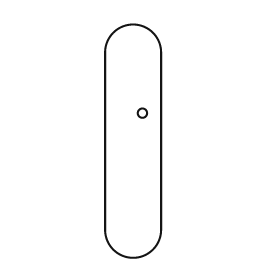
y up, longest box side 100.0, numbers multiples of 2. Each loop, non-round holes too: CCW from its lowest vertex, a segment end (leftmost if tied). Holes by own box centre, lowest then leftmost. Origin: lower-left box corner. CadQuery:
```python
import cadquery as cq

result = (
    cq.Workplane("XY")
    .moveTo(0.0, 12.0)
    .threePointArc((12.0, 0.0), (24.0, 12.0))
    .lineTo(24.0, 88.0)
    .threePointArc((12.0, 100.0), (0.0, 88.0))
    .close()
    .moveTo(16.0, 62.0)
    .circle(2.0)
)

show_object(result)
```